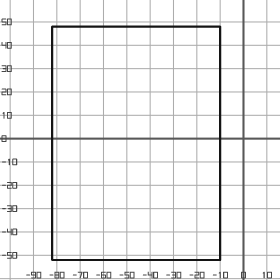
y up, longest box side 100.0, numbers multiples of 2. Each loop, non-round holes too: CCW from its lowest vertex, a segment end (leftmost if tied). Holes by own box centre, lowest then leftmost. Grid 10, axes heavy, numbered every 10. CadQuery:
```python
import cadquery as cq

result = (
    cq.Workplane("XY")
    .moveTo(-82.0, -52.0)
    .lineTo(-10.0, -52.0)
    .lineTo(-10.0, 48.0)
    .lineTo(-82.0, 48.0)
    .close()
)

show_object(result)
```